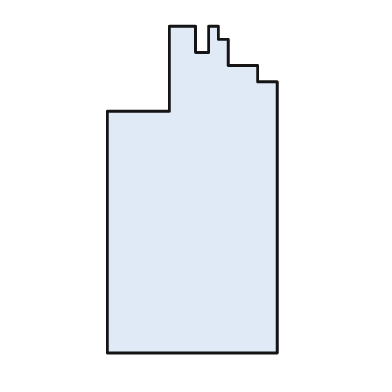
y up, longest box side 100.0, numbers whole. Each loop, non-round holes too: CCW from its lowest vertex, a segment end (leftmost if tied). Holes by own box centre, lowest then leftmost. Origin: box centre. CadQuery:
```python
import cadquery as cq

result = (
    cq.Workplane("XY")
    .moveTo(-26.0, -50.0)
    .lineTo(26.0, -50.0)
    .lineTo(26.0, 33.0)
    .lineTo(20.0, 33.0)
    .lineTo(20.0, 38.0)
    .lineTo(11.0, 38.0)
    .lineTo(11.0, 46.0)
    .lineTo(8.0, 46.0)
    .lineTo(8.0, 50.0)
    .lineTo(5.0, 50.0)
    .lineTo(5.0, 42.0)
    .lineTo(1.0, 42.0)
    .lineTo(1.0, 50.0)
    .lineTo(-7.0, 50.0)
    .lineTo(-7.0, 24.0)
    .lineTo(-26.0, 24.0)
    .close()
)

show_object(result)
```